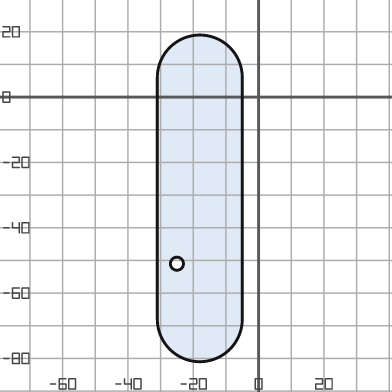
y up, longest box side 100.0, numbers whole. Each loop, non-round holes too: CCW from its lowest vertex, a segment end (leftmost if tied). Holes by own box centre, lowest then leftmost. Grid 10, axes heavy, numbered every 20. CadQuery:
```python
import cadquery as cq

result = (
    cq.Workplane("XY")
    .moveTo(-31.0, -68.0)
    .threePointArc((-18.0, -81.0), (-5.0, -68.0))
    .lineTo(-5.0, 6.0)
    .threePointArc((-18.0, 19.0), (-31.0, 6.0))
    .close()
    .moveTo(-25.0, -51.0)
    .circle(2.0)
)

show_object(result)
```